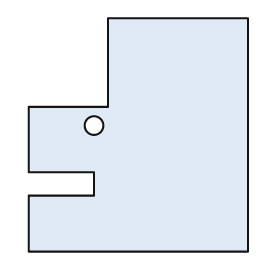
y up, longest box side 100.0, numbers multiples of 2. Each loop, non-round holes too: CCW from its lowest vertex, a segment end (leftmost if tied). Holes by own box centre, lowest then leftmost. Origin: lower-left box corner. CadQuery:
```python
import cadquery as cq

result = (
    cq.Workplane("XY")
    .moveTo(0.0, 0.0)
    .lineTo(94.0, 0.0)
    .lineTo(94.0, 100.0)
    .lineTo(34.0, 100.0)
    .lineTo(34.0, 62.0)
    .lineTo(0.0, 62.0)
    .lineTo(0.0, 34.0)
    .lineTo(28.0, 34.0)
    .lineTo(28.0, 24.0)
    .lineTo(0.0, 24.0)
    .close()
    .moveTo(28.0, 54.0)
    .circle(4.0)
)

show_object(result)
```